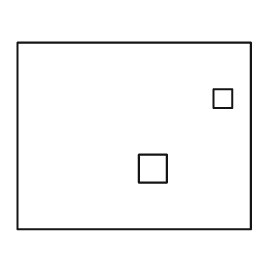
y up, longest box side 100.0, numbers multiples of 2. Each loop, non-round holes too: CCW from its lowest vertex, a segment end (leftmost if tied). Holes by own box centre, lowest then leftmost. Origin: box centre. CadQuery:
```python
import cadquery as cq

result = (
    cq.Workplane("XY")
    .moveTo(-50.0, -40.0)
    .lineTo(50.0, -40.0)
    .lineTo(50.0, 40.0)
    .lineTo(-50.0, 40.0)
    .close()
    .moveTo(2.0, -20.0)
    .lineTo(14.0, -20.0)
    .lineTo(14.0, -8.0)
    .lineTo(2.0, -8.0)
    .close()
    .moveTo(34.0, 12.0)
    .lineTo(42.0, 12.0)
    .lineTo(42.0, 20.0)
    .lineTo(34.0, 20.0)
    .close()
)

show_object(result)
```